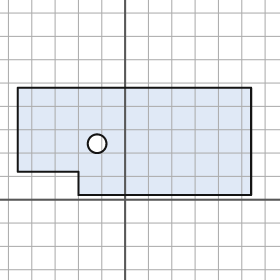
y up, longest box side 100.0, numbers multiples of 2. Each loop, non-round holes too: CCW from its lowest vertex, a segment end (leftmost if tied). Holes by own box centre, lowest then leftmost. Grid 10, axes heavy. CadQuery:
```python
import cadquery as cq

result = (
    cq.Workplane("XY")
    .moveTo(-20.0, 2.0)
    .lineTo(54.0, 2.0)
    .lineTo(54.0, 48.0)
    .lineTo(-46.0, 48.0)
    .lineTo(-46.0, 12.0)
    .lineTo(-20.0, 12.0)
    .close()
    .moveTo(-12.0, 24.0)
    .circle(4.0)
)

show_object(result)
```